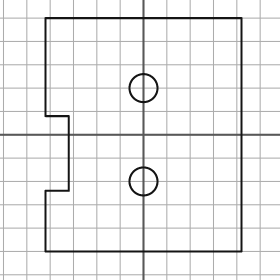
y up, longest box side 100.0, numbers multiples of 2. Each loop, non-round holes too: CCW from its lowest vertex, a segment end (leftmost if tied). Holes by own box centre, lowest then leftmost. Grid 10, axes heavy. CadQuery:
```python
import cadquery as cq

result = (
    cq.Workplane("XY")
    .moveTo(-42.0, -50.0)
    .lineTo(42.0, -50.0)
    .lineTo(42.0, 50.0)
    .lineTo(-42.0, 50.0)
    .lineTo(-42.0, 8.0)
    .lineTo(-32.0, 8.0)
    .lineTo(-32.0, -24.0)
    .lineTo(-42.0, -24.0)
    .close()
    .moveTo(0.0, -20.0)
    .circle(6.0)
    .moveTo(0.0, 20.0)
    .circle(6.0)
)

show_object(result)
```